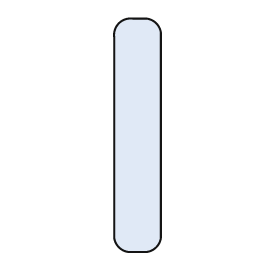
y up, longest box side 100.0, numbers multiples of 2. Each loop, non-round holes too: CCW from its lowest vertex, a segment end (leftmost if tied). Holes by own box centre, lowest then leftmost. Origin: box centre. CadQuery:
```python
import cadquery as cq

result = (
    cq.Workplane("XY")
    .moveTo(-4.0, -50.0)
    .lineTo(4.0, -50.0)
    .threePointArc((8.0, -48.0), (10.0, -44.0))
    .lineTo(10.0, 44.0)
    .threePointArc((8.0, 48.0), (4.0, 50.0))
    .lineTo(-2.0, 50.0)
    .threePointArc((-8.0, 48.0), (-10.0, 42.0))
    .lineTo(-10.0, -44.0)
    .threePointArc((-8.0, -48.0), (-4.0, -50.0))
    .close()
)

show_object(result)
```